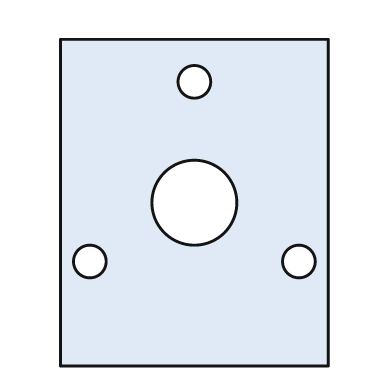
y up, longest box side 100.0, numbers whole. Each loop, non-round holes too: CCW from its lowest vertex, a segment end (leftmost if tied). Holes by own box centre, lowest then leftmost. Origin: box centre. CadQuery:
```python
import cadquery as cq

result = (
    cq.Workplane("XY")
    .moveTo(-41.0, -50.0)
    .lineTo(41.0, -50.0)
    .lineTo(41.0, 50.0)
    .lineTo(-41.0, 50.0)
    .close()
    .moveTo(-32.0, -18.0)
    .circle(5.0)
    .moveTo(32.0, -18.0)
    .circle(5.0)
    .moveTo(0.0, 0.0)
    .circle(13.0)
    .moveTo(0.0, 37.0)
    .circle(5.0)
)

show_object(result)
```